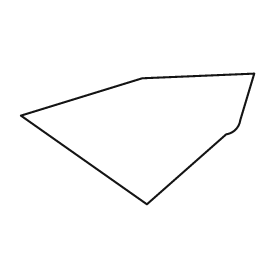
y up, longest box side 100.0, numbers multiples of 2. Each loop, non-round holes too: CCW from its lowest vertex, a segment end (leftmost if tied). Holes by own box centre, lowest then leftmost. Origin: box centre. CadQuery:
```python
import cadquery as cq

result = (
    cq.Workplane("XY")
    .moveTo(4.0, -28.0)
    .lineTo(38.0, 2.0)
    .threePointArc((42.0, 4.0), (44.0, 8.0))
    .lineTo(50.0, 28.0)
    .lineTo(2.0, 26.0)
    .lineTo(-50.0, 10.0)
    .close()
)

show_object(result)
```